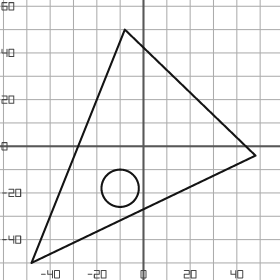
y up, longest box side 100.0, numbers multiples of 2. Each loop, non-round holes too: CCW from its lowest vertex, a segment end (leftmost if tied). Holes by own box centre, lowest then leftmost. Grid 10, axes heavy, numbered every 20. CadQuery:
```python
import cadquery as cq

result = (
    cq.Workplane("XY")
    .moveTo(-48.0, -50.0)
    .lineTo(48.0, -4.0)
    .lineTo(-8.0, 50.0)
    .close()
    .moveTo(-10.0, -18.0)
    .circle(8.0)
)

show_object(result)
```